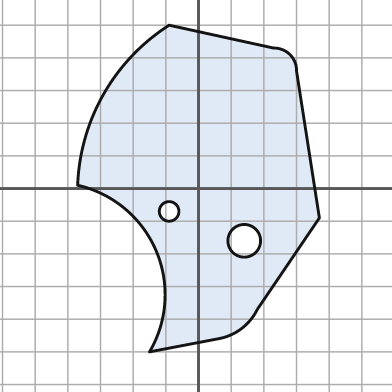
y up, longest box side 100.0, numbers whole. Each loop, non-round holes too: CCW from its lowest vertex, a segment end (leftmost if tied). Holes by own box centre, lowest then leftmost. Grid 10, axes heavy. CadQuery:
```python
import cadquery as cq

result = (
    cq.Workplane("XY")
    .moveTo(-15.0, -50.0)
    .lineTo(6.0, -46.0)
    .threePointArc((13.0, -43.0), (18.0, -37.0))
    .lineTo(37.0, -9.0)
    .lineTo(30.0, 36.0)
    .threePointArc((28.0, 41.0), (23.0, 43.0))
    .lineTo(-9.0, 50.0)
    .threePointArc((-29.0, 29.0), (-37.0, 1.0))
    .threePointArc((-13.0, -19.0), (-15.0, -50.0))
    .close()
    .moveTo(14.0, -16.0)
    .circle(5.0)
    .moveTo(-9.0, -7.0)
    .circle(3.0)
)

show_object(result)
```